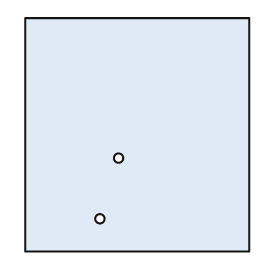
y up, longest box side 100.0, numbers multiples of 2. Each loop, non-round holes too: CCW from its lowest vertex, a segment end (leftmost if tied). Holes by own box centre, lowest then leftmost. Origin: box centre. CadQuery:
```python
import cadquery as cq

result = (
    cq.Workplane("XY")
    .moveTo(-48.0, -50.0)
    .lineTo(48.0, -50.0)
    .lineTo(48.0, 50.0)
    .lineTo(-48.0, 50.0)
    .close()
    .moveTo(-16.0, -36.0)
    .circle(2.0)
    .moveTo(-8.0, -10.0)
    .circle(2.0)
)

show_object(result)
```